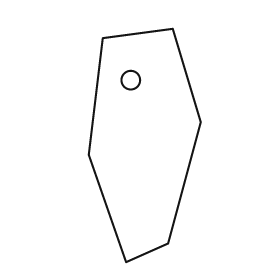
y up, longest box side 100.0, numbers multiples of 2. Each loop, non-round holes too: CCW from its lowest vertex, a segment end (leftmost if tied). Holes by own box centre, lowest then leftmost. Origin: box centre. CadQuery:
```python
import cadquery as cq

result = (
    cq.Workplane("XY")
    .moveTo(-8.0, -50.0)
    .lineTo(10.0, -42.0)
    .lineTo(24.0, 10.0)
    .lineTo(12.0, 50.0)
    .lineTo(-18.0, 46.0)
    .lineTo(-24.0, -4.0)
    .close()
    .moveTo(-6.0, 28.0)
    .circle(4.0)
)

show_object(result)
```